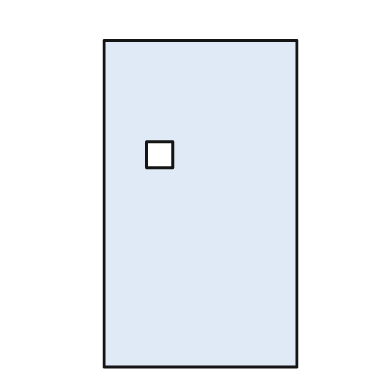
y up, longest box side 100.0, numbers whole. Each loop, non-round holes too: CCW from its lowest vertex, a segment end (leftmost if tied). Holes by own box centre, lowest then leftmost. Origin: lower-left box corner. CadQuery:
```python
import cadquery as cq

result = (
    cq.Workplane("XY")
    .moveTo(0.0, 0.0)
    .lineTo(59.0, 0.0)
    .lineTo(59.0, 100.0)
    .lineTo(0.0, 100.0)
    .close()
    .moveTo(13.0, 61.0)
    .lineTo(21.0, 61.0)
    .lineTo(21.0, 69.0)
    .lineTo(13.0, 69.0)
    .close()
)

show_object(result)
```